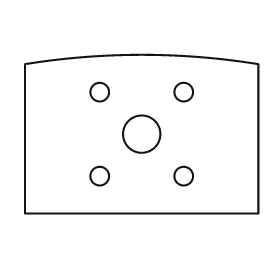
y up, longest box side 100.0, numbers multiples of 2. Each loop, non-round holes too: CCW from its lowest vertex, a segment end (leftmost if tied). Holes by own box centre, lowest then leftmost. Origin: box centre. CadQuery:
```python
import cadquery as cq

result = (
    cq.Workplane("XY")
    .moveTo(-50.0, -34.0)
    .lineTo(50.0, -34.0)
    .lineTo(50.0, 30.0)
    .threePointArc((0.0, 34.0), (-50.0, 30.0))
    .close()
    .moveTo(-18.0, -18.0)
    .circle(4.0)
    .moveTo(18.0, -18.0)
    .circle(4.0)
    .moveTo(0.0, 0.0)
    .circle(8.0)
    .moveTo(-18.0, 18.0)
    .circle(4.0)
    .moveTo(18.0, 18.0)
    .circle(4.0)
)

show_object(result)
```